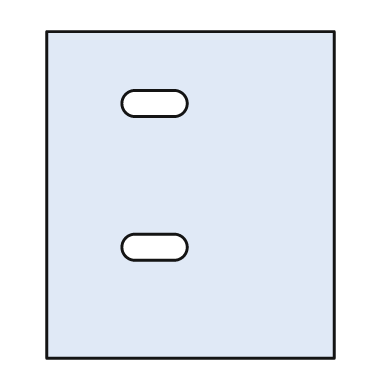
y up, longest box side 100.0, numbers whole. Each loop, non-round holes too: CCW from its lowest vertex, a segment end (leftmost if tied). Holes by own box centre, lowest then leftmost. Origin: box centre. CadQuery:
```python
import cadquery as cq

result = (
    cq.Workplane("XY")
    .moveTo(-44.0, -50.0)
    .lineTo(44.0, -50.0)
    .lineTo(44.0, 50.0)
    .lineTo(-44.0, 50.0)
    .close()
    .moveTo(-17.0, -20.0)
    .lineTo(-5.0, -20.0)
    .threePointArc((-1.0, -16.0), (-5.0, -12.0))
    .lineTo(-17.0, -12.0)
    .threePointArc((-21.0, -16.0), (-17.0, -20.0))
    .close()
    .moveTo(-17.0, 24.0)
    .lineTo(-5.0, 24.0)
    .threePointArc((-1.0, 28.0), (-5.0, 32.0))
    .lineTo(-17.0, 32.0)
    .threePointArc((-21.0, 28.0), (-17.0, 24.0))
    .close()
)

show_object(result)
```